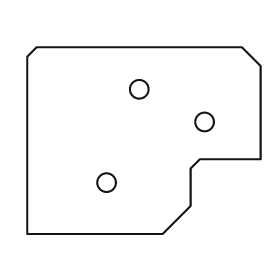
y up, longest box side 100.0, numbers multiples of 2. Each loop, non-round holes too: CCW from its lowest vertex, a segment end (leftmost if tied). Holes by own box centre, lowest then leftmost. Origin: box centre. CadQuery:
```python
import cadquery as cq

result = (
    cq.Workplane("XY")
    .moveTo(-50.0, -40.0)
    .lineTo(8.0, -40.0)
    .lineTo(20.0, -28.0)
    .lineTo(20.0, -12.0)
    .lineTo(24.0, -8.0)
    .lineTo(50.0, -8.0)
    .lineTo(50.0, 32.0)
    .lineTo(42.0, 40.0)
    .lineTo(-46.0, 40.0)
    .lineTo(-50.0, 36.0)
    .close()
    .moveTo(-16.0, -18.0)
    .circle(4.0)
    .moveTo(26.0, 8.0)
    .circle(4.0)
    .moveTo(-2.0, 22.0)
    .circle(4.0)
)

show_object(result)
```